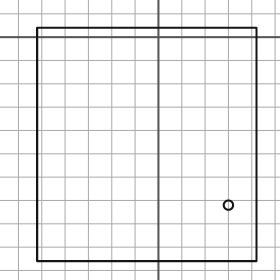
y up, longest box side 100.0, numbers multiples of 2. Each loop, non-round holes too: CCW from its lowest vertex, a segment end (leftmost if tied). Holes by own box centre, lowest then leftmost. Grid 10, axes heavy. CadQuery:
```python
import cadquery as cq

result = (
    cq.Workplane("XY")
    .moveTo(-52.0, -96.0)
    .lineTo(42.0, -96.0)
    .lineTo(42.0, 4.0)
    .lineTo(-52.0, 4.0)
    .close()
    .moveTo(30.0, -72.0)
    .circle(2.0)
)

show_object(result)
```